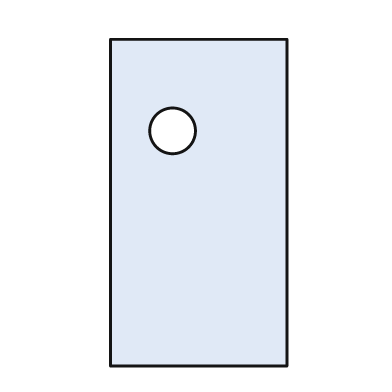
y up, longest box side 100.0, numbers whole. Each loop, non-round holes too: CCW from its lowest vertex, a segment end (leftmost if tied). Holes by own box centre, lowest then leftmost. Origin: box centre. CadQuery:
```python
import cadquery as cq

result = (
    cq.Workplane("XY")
    .moveTo(-27.0, -50.0)
    .lineTo(27.0, -50.0)
    .lineTo(27.0, 50.0)
    .lineTo(-27.0, 50.0)
    .close()
    .moveTo(-8.0, 22.0)
    .circle(7.0)
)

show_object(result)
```